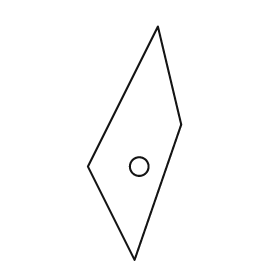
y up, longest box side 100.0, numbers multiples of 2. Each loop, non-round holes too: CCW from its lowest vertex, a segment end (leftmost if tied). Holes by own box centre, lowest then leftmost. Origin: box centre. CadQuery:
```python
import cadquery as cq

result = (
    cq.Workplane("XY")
    .moveTo(0.0, -50.0)
    .lineTo(20.0, 8.0)
    .lineTo(10.0, 50.0)
    .lineTo(-20.0, -10.0)
    .close()
    .moveTo(2.0, -10.0)
    .circle(4.0)
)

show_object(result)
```